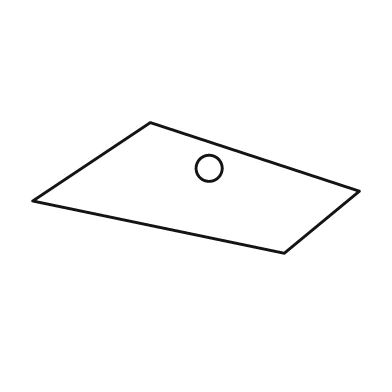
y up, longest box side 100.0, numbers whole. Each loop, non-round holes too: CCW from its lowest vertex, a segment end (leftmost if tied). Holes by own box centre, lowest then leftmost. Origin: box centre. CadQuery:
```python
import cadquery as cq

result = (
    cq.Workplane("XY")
    .moveTo(27.0, -20.0)
    .lineTo(50.0, -1.0)
    .lineTo(-14.0, 20.0)
    .lineTo(-50.0, -4.0)
    .close()
    .moveTo(4.0, 6.0)
    .circle(4.0)
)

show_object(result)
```